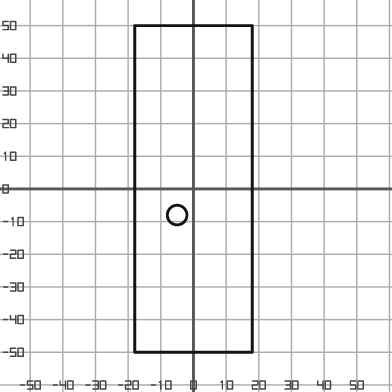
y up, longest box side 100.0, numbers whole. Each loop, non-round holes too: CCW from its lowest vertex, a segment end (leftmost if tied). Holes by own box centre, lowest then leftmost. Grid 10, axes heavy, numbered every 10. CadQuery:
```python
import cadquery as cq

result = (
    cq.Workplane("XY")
    .moveTo(-18.0, -50.0)
    .lineTo(18.0, -50.0)
    .lineTo(18.0, 50.0)
    .lineTo(-18.0, 50.0)
    .close()
    .moveTo(-5.0, -8.0)
    .circle(3.0)
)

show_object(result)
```